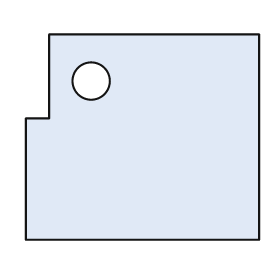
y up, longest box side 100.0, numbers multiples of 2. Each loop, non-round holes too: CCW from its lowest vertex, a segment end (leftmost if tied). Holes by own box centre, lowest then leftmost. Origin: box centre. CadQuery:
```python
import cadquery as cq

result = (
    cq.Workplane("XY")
    .moveTo(-50.0, -44.0)
    .lineTo(50.0, -44.0)
    .lineTo(50.0, 44.0)
    .lineTo(-40.0, 44.0)
    .lineTo(-40.0, 8.0)
    .lineTo(-50.0, 8.0)
    .close()
    .moveTo(-22.0, 24.0)
    .circle(8.0)
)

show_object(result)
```